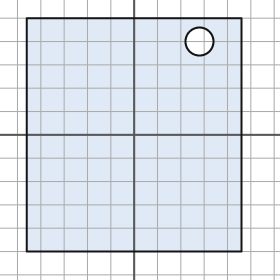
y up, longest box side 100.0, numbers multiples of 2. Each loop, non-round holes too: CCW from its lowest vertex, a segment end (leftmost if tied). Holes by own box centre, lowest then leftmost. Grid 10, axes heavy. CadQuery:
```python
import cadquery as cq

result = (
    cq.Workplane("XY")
    .moveTo(-46.0, -50.0)
    .lineTo(46.0, -50.0)
    .lineTo(46.0, 50.0)
    .lineTo(-46.0, 50.0)
    .close()
    .moveTo(28.0, 40.0)
    .circle(6.0)
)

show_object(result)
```